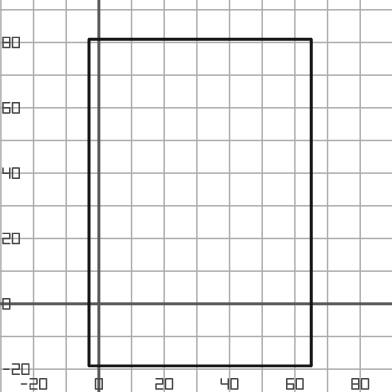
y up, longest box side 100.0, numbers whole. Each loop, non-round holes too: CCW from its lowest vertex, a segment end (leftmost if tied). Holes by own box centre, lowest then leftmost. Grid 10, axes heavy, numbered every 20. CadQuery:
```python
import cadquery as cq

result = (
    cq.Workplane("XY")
    .moveTo(-3.0, -19.0)
    .lineTo(65.0, -19.0)
    .lineTo(65.0, 81.0)
    .lineTo(-3.0, 81.0)
    .close()
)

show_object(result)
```